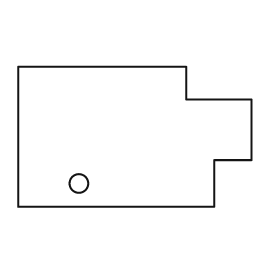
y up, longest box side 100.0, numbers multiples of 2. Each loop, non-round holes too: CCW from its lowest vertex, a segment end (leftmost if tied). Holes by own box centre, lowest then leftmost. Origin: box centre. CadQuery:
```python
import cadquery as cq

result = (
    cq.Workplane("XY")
    .moveTo(-50.0, -30.0)
    .lineTo(34.0, -30.0)
    .lineTo(34.0, -10.0)
    .lineTo(50.0, -10.0)
    .lineTo(50.0, 16.0)
    .lineTo(22.0, 16.0)
    .lineTo(22.0, 30.0)
    .lineTo(-50.0, 30.0)
    .close()
    .moveTo(-24.0, -20.0)
    .circle(4.0)
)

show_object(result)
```